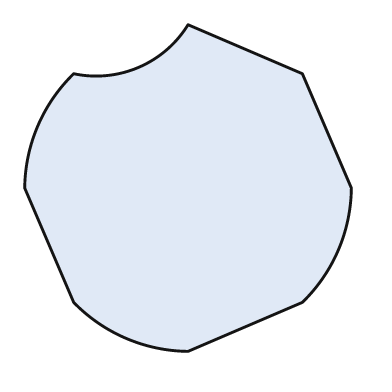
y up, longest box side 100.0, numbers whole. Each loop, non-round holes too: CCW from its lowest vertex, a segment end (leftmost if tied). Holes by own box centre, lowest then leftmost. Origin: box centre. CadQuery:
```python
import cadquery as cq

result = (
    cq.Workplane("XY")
    .moveTo(0.0, -50.0)
    .lineTo(35.0, -35.0)
    .threePointArc((46.0, -19.0), (50.0, 0.0))
    .lineTo(35.0, 35.0)
    .lineTo(0.0, 50.0)
    .threePointArc((-15.0, 37.0), (-35.0, 35.0))
    .threePointArc((-46.0, 19.0), (-50.0, 0.0))
    .lineTo(-35.0, -35.0)
    .threePointArc((-19.0, -46.0), (0.0, -50.0))
    .close()
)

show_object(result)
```